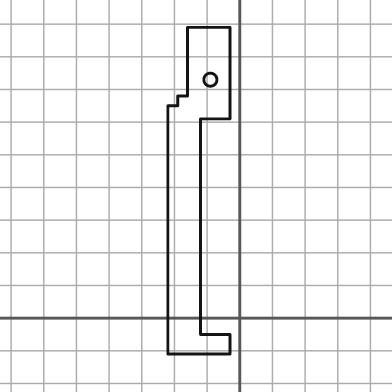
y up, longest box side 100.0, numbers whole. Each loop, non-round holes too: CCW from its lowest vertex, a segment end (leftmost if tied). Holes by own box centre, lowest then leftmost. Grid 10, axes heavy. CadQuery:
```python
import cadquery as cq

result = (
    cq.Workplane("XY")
    .moveTo(-22.0, -11.0)
    .lineTo(-3.0, -11.0)
    .lineTo(-3.0, -5.0)
    .lineTo(-12.0, -5.0)
    .lineTo(-12.0, 61.0)
    .lineTo(-3.0, 61.0)
    .lineTo(-3.0, 89.0)
    .lineTo(-16.0, 89.0)
    .lineTo(-16.0, 68.0)
    .lineTo(-19.0, 68.0)
    .lineTo(-19.0, 65.0)
    .lineTo(-22.0, 65.0)
    .close()
    .moveTo(-9.0, 73.0)
    .circle(2.0)
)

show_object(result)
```